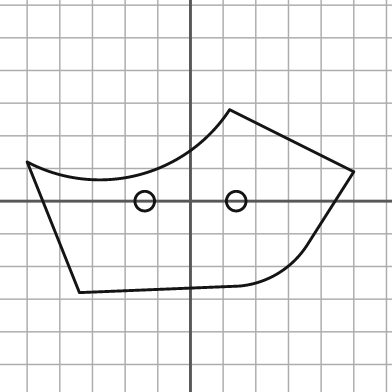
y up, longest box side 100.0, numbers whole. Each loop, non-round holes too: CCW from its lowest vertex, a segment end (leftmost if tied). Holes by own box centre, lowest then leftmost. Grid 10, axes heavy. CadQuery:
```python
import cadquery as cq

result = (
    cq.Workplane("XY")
    .moveTo(-34.0, -28.0)
    .lineTo(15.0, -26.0)
    .threePointArc((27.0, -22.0), (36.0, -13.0))
    .lineTo(50.0, 9.0)
    .lineTo(12.0, 28.0)
    .threePointArc((-16.0, 8.0), (-50.0, 12.0))
    .close()
    .moveTo(-14.0, 0.0)
    .circle(3.0)
    .moveTo(14.0, 0.0)
    .circle(3.0)
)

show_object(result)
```